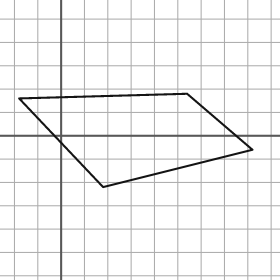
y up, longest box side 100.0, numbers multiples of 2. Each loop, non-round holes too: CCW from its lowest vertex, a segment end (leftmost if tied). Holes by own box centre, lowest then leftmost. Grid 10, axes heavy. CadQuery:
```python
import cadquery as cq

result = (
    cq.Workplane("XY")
    .moveTo(18.0, -22.0)
    .lineTo(82.0, -6.0)
    .lineTo(54.0, 18.0)
    .lineTo(-18.0, 16.0)
    .close()
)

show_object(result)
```